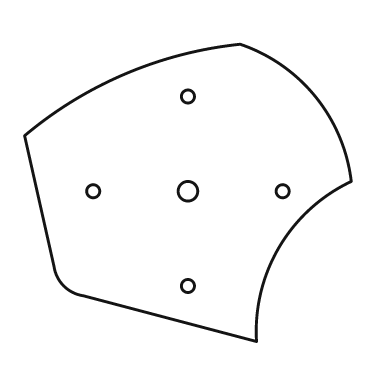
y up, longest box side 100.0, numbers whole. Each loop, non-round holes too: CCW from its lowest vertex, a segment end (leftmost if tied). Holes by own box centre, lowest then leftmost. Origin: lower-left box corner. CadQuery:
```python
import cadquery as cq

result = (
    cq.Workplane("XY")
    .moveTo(71.0, 0.0)
    .threePointArc((78.0, 29.0), (100.0, 49.0))
    .threePointArc((89.0, 75.0), (66.0, 91.0))
    .threePointArc((31.0, 82.0), (0.0, 63.0))
    .lineTo(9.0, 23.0)
    .threePointArc((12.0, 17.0), (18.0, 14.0))
    .close()
    .moveTo(50.0, 17.0)
    .circle(2.0)
    .moveTo(21.0, 46.0)
    .circle(2.0)
    .moveTo(50.0, 46.0)
    .circle(3.0)
    .moveTo(79.0, 46.0)
    .circle(2.0)
    .moveTo(50.0, 75.0)
    .circle(2.0)
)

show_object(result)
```